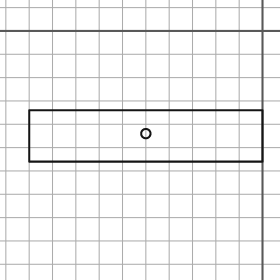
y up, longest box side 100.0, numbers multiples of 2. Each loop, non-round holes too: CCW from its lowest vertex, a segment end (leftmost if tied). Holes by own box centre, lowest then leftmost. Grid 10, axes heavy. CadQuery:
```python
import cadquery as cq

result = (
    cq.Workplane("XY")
    .moveTo(-100.0, -56.0)
    .lineTo(0.0, -56.0)
    .lineTo(0.0, -34.0)
    .lineTo(-100.0, -34.0)
    .close()
    .moveTo(-50.0, -44.0)
    .circle(2.0)
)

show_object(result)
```